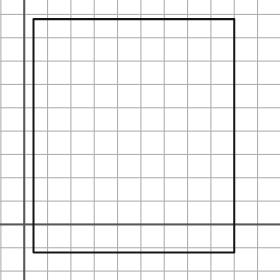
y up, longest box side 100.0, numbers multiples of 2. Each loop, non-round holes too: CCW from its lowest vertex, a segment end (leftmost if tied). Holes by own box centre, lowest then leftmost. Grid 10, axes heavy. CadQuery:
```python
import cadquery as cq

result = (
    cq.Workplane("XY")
    .moveTo(4.0, -12.0)
    .lineTo(90.0, -12.0)
    .lineTo(90.0, 88.0)
    .lineTo(4.0, 88.0)
    .close()
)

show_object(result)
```